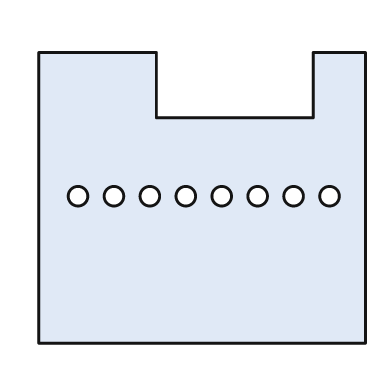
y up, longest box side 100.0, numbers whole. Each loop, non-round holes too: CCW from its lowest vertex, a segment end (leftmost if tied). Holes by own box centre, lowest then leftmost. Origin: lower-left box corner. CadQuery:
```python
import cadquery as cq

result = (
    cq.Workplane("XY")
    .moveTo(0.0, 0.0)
    .lineTo(100.0, 0.0)
    .lineTo(100.0, 89.0)
    .lineTo(84.0, 89.0)
    .lineTo(84.0, 69.0)
    .lineTo(36.0, 69.0)
    .lineTo(36.0, 89.0)
    .lineTo(0.0, 89.0)
    .close()
    .moveTo(12.0, 45.0)
    .circle(3.0)
    .moveTo(23.0, 45.0)
    .circle(3.0)
    .moveTo(34.0, 45.0)
    .circle(3.0)
    .moveTo(45.0, 45.0)
    .circle(3.0)
    .moveTo(56.0, 45.0)
    .circle(3.0)
    .moveTo(67.0, 45.0)
    .circle(3.0)
    .moveTo(78.0, 45.0)
    .circle(3.0)
    .moveTo(89.0, 45.0)
    .circle(3.0)
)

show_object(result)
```